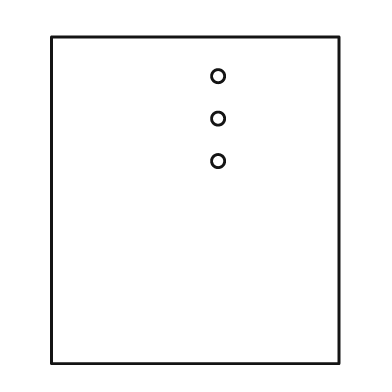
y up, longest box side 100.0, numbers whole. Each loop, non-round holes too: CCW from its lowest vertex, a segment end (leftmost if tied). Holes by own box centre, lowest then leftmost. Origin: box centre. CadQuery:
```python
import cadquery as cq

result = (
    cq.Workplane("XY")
    .moveTo(-44.0, -50.0)
    .lineTo(44.0, -50.0)
    .lineTo(44.0, 50.0)
    .lineTo(-44.0, 50.0)
    .close()
    .moveTo(7.0, 12.0)
    .circle(2.0)
    .moveTo(7.0, 25.0)
    .circle(2.0)
    .moveTo(7.0, 38.0)
    .circle(2.0)
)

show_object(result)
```